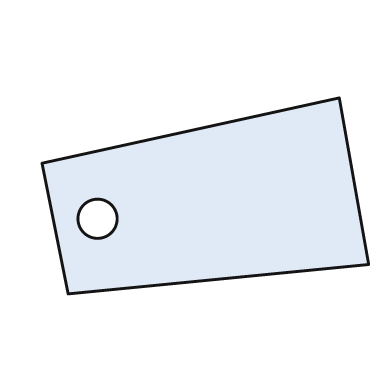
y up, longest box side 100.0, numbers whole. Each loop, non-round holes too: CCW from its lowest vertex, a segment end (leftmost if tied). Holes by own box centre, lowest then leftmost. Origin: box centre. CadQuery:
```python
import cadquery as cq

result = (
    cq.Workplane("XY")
    .moveTo(-42.0, -30.0)
    .lineTo(50.0, -21.0)
    .lineTo(41.0, 30.0)
    .lineTo(-50.0, 10.0)
    .close()
    .moveTo(-33.0, -7.0)
    .circle(6.0)
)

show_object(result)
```